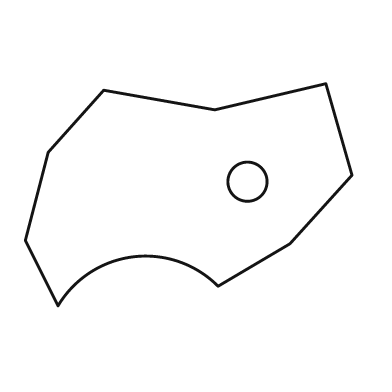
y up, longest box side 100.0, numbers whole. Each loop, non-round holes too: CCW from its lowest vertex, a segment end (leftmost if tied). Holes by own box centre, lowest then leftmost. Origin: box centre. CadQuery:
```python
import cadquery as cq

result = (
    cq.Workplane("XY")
    .moveTo(-40.0, -34.0)
    .threePointArc((-17.0, -19.0), (9.0, -28.0))
    .lineTo(31.0, -15.0)
    .lineTo(50.0, 6.0)
    .lineTo(42.0, 34.0)
    .lineTo(8.0, 26.0)
    .lineTo(-26.0, 32.0)
    .lineTo(-43.0, 13.0)
    .lineTo(-50.0, -14.0)
    .close()
    .moveTo(18.0, 4.0)
    .circle(6.0)
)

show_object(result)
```